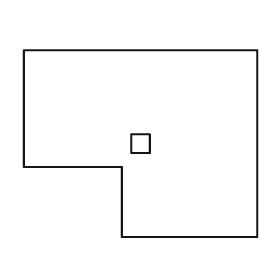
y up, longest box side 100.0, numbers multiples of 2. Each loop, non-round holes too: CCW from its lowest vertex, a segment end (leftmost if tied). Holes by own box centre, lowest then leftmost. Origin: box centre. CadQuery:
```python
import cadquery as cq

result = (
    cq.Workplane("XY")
    .moveTo(-8.0, -40.0)
    .lineTo(50.0, -40.0)
    .lineTo(50.0, 40.0)
    .lineTo(-50.0, 40.0)
    .lineTo(-50.0, -10.0)
    .lineTo(-8.0, -10.0)
    .close()
    .moveTo(-4.0, -4.0)
    .lineTo(4.0, -4.0)
    .lineTo(4.0, 4.0)
    .lineTo(-4.0, 4.0)
    .close()
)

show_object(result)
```